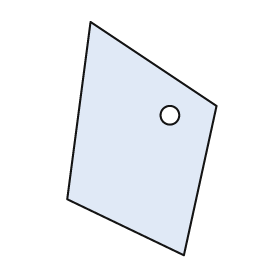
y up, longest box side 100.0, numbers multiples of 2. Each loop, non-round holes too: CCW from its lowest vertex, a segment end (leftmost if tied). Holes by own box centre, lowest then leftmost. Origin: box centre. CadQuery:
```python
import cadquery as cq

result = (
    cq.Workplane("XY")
    .moveTo(18.0, -50.0)
    .lineTo(32.0, 14.0)
    .lineTo(-22.0, 50.0)
    .lineTo(-32.0, -26.0)
    .close()
    .moveTo(12.0, 10.0)
    .circle(4.0)
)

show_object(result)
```